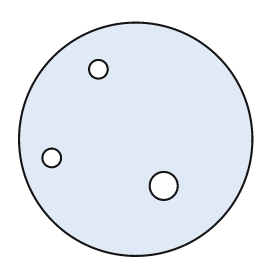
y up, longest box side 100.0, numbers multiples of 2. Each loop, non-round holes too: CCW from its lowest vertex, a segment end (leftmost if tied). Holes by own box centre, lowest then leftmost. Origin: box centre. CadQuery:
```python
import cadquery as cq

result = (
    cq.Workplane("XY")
    .moveTo(0.0, 0.0)
    .circle(50.0)
    .moveTo(12.0, -20.0)
    .circle(6.0)
    .moveTo(-36.0, -8.0)
    .circle(4.0)
    .moveTo(-16.0, 30.0)
    .circle(4.0)
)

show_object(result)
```